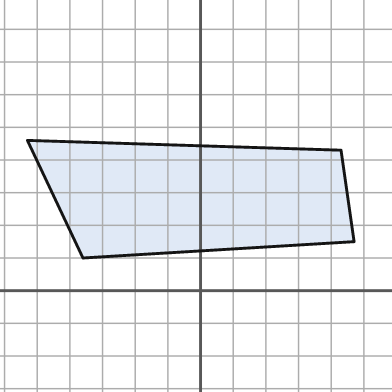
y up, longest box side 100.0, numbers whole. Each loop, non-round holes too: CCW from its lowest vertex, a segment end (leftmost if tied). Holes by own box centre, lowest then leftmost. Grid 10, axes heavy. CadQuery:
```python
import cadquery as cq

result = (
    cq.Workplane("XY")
    .moveTo(-36.0, 10.0)
    .lineTo(47.0, 15.0)
    .lineTo(43.0, 43.0)
    .lineTo(-53.0, 46.0)
    .close()
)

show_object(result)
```